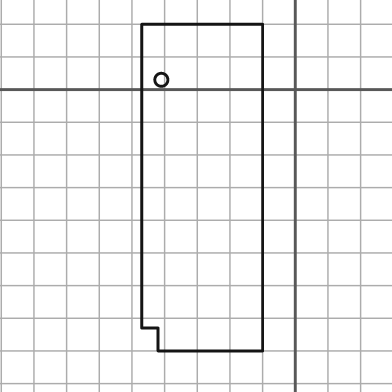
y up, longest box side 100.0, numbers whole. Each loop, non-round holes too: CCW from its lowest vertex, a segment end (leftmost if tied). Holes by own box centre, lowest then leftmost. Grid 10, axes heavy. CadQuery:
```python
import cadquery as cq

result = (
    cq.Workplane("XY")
    .moveTo(-42.0, -80.0)
    .lineTo(-10.0, -80.0)
    .lineTo(-10.0, 20.0)
    .lineTo(-47.0, 20.0)
    .lineTo(-47.0, -73.0)
    .lineTo(-42.0, -73.0)
    .close()
    .moveTo(-41.0, 3.0)
    .circle(2.0)
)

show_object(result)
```